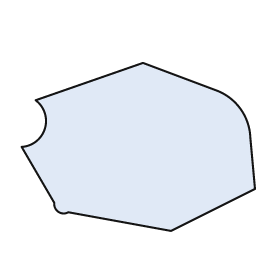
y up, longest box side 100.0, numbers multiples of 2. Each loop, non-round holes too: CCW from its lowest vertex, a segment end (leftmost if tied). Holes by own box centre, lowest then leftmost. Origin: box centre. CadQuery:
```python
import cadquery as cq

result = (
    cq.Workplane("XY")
    .moveTo(14.0, -36.0)
    .lineTo(50.0, -18.0)
    .lineTo(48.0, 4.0)
    .threePointArc((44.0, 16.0), (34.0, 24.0))
    .lineTo(2.0, 36.0)
    .lineTo(-44.0, 20.0)
    .threePointArc((-40.0, 8.0), (-50.0, 0.0))
    .lineTo(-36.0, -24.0)
    .threePointArc((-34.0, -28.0), (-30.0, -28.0))
    .close()
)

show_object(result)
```